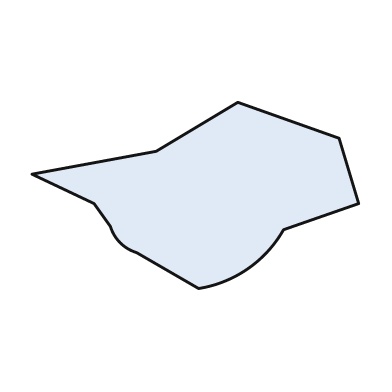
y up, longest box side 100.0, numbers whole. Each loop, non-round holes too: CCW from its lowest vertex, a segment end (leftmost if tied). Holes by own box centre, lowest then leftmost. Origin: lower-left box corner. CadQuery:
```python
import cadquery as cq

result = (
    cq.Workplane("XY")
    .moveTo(51.0, 0.0)
    .threePointArc((66.0, 6.0), (77.0, 18.0))
    .lineTo(100.0, 26.0)
    .lineTo(94.0, 46.0)
    .lineTo(63.0, 57.0)
    .lineTo(38.0, 42.0)
    .lineTo(0.0, 35.0)
    .lineTo(19.0, 26.0)
    .lineTo(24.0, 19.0)
    .threePointArc((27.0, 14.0), (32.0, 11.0))
    .close()
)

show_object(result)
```